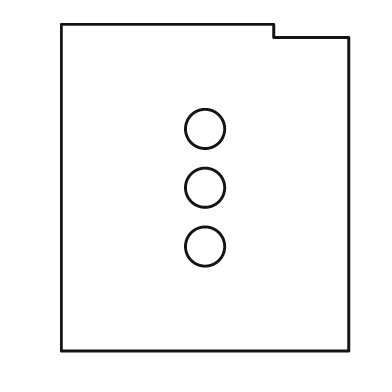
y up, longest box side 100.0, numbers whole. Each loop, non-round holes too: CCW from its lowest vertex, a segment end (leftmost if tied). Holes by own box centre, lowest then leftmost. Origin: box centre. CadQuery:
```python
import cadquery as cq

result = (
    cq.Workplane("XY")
    .moveTo(-44.0, -50.0)
    .lineTo(44.0, -50.0)
    .lineTo(44.0, 46.0)
    .lineTo(21.0, 46.0)
    .lineTo(21.0, 50.0)
    .lineTo(-44.0, 50.0)
    .close()
    .moveTo(0.0, -18.0)
    .circle(6.0)
    .moveTo(0.0, 0.0)
    .circle(6.0)
    .moveTo(0.0, 18.0)
    .circle(6.0)
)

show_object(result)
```